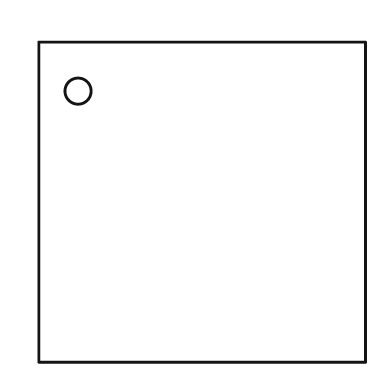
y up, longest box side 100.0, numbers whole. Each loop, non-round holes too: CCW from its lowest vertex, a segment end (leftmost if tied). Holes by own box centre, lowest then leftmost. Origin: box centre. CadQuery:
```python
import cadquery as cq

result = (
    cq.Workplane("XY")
    .moveTo(-50.0, -49.0)
    .lineTo(50.0, -49.0)
    .lineTo(50.0, 49.0)
    .lineTo(-50.0, 49.0)
    .close()
    .moveTo(-38.0, 34.0)
    .circle(4.0)
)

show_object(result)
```